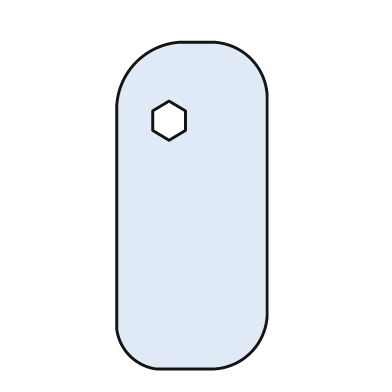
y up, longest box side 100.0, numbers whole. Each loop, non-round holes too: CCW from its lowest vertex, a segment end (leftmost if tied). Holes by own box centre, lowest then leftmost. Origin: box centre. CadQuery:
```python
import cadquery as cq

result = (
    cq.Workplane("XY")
    .moveTo(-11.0, -50.0)
    .lineTo(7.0, -50.0)
    .threePointArc((18.0, -45.0), (23.0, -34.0))
    .lineTo(23.0, 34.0)
    .threePointArc((18.0, 45.0), (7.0, 50.0))
    .lineTo(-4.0, 50.0)
    .threePointArc((-17.0, 44.0), (-23.0, 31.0))
    .lineTo(-23.0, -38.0)
    .threePointArc((-19.0, -46.0), (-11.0, -50.0))
    .close()
    .moveTo(-7.0, 20.0)
    .lineTo(-2.0, 23.0)
    .lineTo(-2.0, 29.0)
    .lineTo(-7.0, 32.0)
    .lineTo(-12.0, 29.0)
    .lineTo(-12.0, 23.0)
    .close()
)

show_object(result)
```